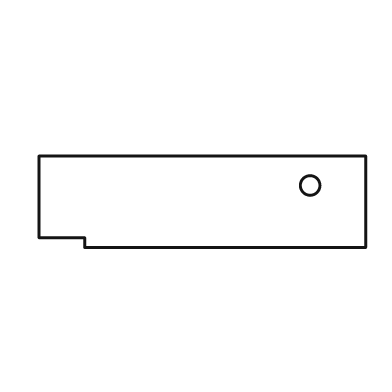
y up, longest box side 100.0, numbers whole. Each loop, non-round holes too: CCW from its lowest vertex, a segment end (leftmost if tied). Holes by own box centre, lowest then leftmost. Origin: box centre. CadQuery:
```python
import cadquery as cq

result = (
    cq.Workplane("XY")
    .moveTo(-36.0, -14.0)
    .lineTo(50.0, -14.0)
    .lineTo(50.0, 14.0)
    .lineTo(-50.0, 14.0)
    .lineTo(-50.0, -11.0)
    .lineTo(-36.0, -11.0)
    .close()
    .moveTo(33.0, 5.0)
    .circle(3.0)
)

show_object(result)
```